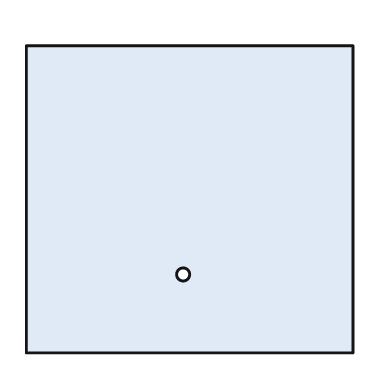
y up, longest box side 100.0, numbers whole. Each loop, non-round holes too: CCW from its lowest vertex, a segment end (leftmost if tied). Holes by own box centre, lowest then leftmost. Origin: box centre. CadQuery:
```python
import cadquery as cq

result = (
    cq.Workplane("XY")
    .moveTo(-50.0, -47.0)
    .lineTo(50.0, -47.0)
    .lineTo(50.0, 47.0)
    .lineTo(-50.0, 47.0)
    .close()
    .moveTo(-2.0, -23.0)
    .circle(2.0)
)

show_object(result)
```